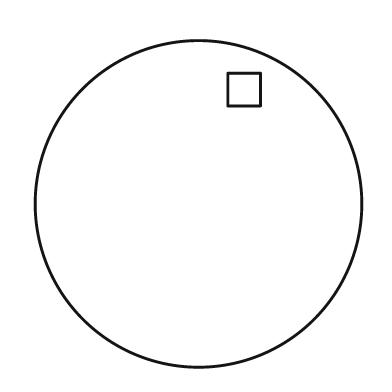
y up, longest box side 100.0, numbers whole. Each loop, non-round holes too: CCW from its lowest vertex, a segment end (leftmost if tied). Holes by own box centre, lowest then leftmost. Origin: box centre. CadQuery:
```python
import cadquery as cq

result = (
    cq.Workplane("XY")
    .moveTo(0.0, 0.0)
    .circle(50.0)
    .moveTo(9.0, 30.0)
    .lineTo(19.0, 30.0)
    .lineTo(19.0, 40.0)
    .lineTo(9.0, 40.0)
    .close()
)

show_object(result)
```